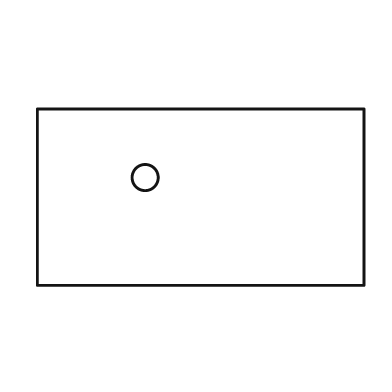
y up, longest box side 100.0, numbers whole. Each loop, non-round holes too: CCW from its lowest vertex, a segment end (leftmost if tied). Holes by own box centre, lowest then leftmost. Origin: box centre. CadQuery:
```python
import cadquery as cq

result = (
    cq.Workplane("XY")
    .moveTo(-50.0, -27.0)
    .lineTo(50.0, -27.0)
    .lineTo(50.0, 27.0)
    .lineTo(-50.0, 27.0)
    .close()
    .moveTo(-17.0, 6.0)
    .circle(4.0)
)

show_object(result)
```